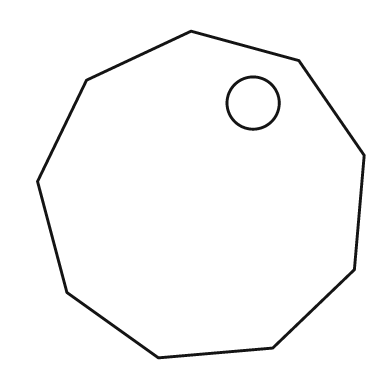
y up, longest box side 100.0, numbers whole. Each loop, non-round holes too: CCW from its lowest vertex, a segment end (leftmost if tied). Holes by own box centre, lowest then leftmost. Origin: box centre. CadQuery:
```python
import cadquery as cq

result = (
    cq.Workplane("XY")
    .moveTo(-13.0, -50.0)
    .lineTo(22.0, -47.0)
    .lineTo(47.0, -23.0)
    .lineTo(50.0, 12.0)
    .lineTo(30.0, 41.0)
    .lineTo(-3.0, 50.0)
    .lineTo(-35.0, 35.0)
    .lineTo(-50.0, 4.0)
    .lineTo(-41.0, -30.0)
    .close()
    .moveTo(16.0, 28.0)
    .circle(8.0)
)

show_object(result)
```